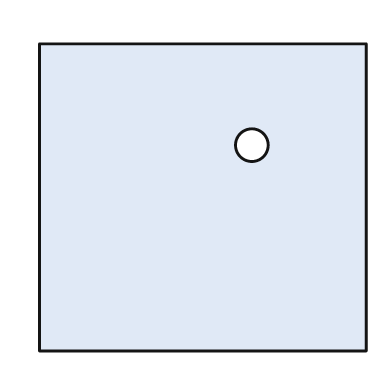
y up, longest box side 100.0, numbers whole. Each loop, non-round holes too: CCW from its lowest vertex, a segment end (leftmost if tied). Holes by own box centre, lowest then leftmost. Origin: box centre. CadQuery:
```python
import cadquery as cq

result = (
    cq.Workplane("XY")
    .moveTo(-50.0, -47.0)
    .lineTo(50.0, -47.0)
    .lineTo(50.0, 47.0)
    .lineTo(-50.0, 47.0)
    .close()
    .moveTo(15.0, 16.0)
    .circle(5.0)
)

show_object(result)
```